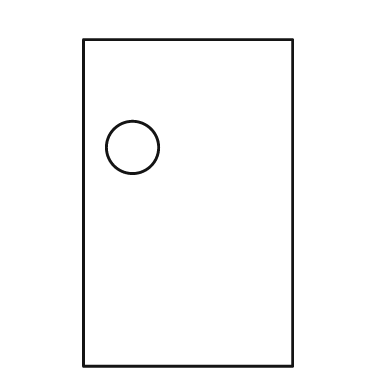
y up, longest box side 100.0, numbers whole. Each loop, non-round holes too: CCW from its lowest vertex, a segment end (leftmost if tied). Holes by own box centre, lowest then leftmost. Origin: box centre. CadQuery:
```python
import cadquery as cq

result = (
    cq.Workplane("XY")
    .moveTo(-32.0, -50.0)
    .lineTo(32.0, -50.0)
    .lineTo(32.0, 50.0)
    .lineTo(-32.0, 50.0)
    .close()
    .moveTo(-17.0, 17.0)
    .circle(8.0)
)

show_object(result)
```